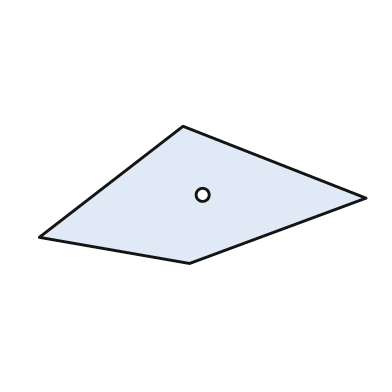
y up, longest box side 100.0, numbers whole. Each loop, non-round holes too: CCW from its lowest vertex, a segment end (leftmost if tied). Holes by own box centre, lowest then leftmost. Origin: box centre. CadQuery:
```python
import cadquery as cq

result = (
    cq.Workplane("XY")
    .moveTo(-4.0, -21.0)
    .lineTo(50.0, -1.0)
    .lineTo(-6.0, 21.0)
    .lineTo(-50.0, -13.0)
    .close()
    .moveTo(0.0, 0.0)
    .circle(2.0)
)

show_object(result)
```